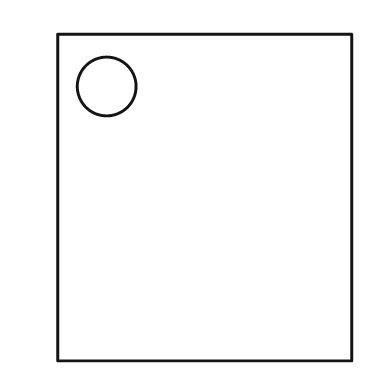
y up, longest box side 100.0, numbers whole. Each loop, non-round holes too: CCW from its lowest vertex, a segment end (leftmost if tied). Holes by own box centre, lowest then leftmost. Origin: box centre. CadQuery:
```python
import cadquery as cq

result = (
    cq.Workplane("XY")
    .moveTo(-45.0, -50.0)
    .lineTo(45.0, -50.0)
    .lineTo(45.0, 50.0)
    .lineTo(-45.0, 50.0)
    .close()
    .moveTo(-30.0, 34.0)
    .circle(9.0)
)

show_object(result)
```